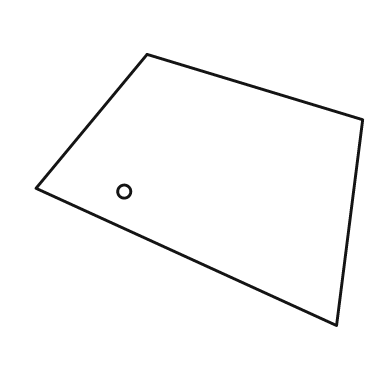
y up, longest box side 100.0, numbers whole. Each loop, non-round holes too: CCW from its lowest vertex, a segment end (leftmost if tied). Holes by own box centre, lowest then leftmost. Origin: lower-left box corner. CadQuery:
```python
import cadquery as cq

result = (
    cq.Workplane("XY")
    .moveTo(92.0, 0.0)
    .lineTo(100.0, 63.0)
    .lineTo(34.0, 83.0)
    .lineTo(0.0, 42.0)
    .close()
    .moveTo(27.0, 41.0)
    .circle(2.0)
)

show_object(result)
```